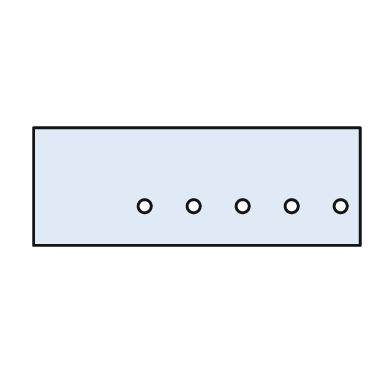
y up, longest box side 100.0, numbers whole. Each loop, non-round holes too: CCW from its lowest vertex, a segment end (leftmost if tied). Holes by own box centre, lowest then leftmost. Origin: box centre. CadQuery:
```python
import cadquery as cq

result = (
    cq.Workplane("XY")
    .moveTo(-50.0, -18.0)
    .lineTo(50.0, -18.0)
    .lineTo(50.0, 18.0)
    .lineTo(-50.0, 18.0)
    .close()
    .moveTo(-16.0, -6.0)
    .circle(2.0)
    .moveTo(-1.0, -6.0)
    .circle(2.0)
    .moveTo(14.0, -6.0)
    .circle(2.0)
    .moveTo(29.0, -6.0)
    .circle(2.0)
    .moveTo(44.0, -6.0)
    .circle(2.0)
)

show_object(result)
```